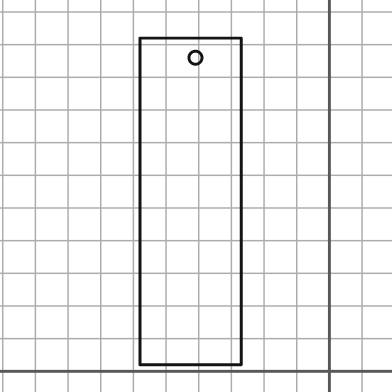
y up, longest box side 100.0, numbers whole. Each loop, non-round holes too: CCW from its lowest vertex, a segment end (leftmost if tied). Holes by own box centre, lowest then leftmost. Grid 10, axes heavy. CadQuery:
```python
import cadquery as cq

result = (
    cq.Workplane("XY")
    .moveTo(-58.0, 2.0)
    .lineTo(-27.0, 2.0)
    .lineTo(-27.0, 102.0)
    .lineTo(-58.0, 102.0)
    .close()
    .moveTo(-41.0, 96.0)
    .circle(2.0)
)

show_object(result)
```